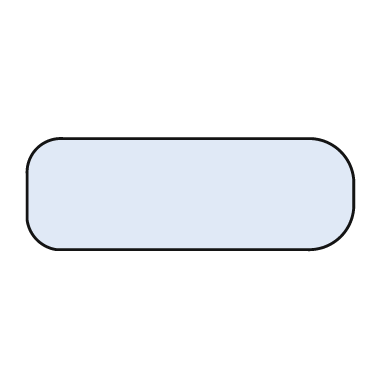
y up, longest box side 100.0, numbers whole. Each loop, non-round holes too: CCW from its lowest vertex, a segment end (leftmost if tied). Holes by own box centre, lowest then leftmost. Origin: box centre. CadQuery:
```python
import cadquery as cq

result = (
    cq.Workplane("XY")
    .moveTo(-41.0, -17.0)
    .lineTo(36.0, -17.0)
    .threePointArc((46.0, -13.0), (50.0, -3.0))
    .lineTo(50.0, 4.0)
    .threePointArc((46.0, 13.0), (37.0, 17.0))
    .lineTo(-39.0, 17.0)
    .threePointArc((-47.0, 14.0), (-50.0, 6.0))
    .lineTo(-50.0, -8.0)
    .threePointArc((-47.0, -14.0), (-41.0, -17.0))
    .close()
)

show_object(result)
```